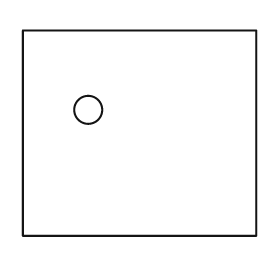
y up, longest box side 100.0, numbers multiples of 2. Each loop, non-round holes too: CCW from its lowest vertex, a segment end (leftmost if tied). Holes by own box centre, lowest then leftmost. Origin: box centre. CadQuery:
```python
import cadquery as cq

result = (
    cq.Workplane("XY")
    .moveTo(-50.0, -44.0)
    .lineTo(50.0, -44.0)
    .lineTo(50.0, 44.0)
    .lineTo(-50.0, 44.0)
    .close()
    .moveTo(-22.0, 10.0)
    .circle(6.0)
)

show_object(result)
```